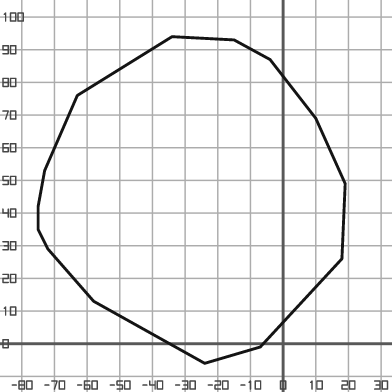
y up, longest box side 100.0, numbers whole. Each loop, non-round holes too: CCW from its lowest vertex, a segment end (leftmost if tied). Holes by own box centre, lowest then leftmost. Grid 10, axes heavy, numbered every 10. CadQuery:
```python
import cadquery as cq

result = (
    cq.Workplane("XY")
    .moveTo(-24.0, -6.0)
    .lineTo(-7.0, -1.0)
    .lineTo(18.0, 26.0)
    .lineTo(19.0, 49.0)
    .lineTo(10.0, 69.0)
    .lineTo(-4.0, 87.0)
    .lineTo(-15.0, 93.0)
    .lineTo(-34.0, 94.0)
    .lineTo(-63.0, 76.0)
    .lineTo(-73.0, 53.0)
    .lineTo(-75.0, 42.0)
    .lineTo(-75.0, 35.0)
    .lineTo(-72.0, 29.0)
    .lineTo(-58.0, 13.0)
    .close()
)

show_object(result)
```